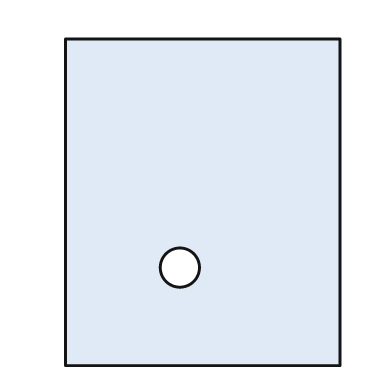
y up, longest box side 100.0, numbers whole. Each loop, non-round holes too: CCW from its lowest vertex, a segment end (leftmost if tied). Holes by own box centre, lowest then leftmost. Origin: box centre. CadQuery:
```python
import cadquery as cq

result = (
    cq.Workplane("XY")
    .moveTo(-42.0, -50.0)
    .lineTo(42.0, -50.0)
    .lineTo(42.0, 50.0)
    .lineTo(-42.0, 50.0)
    .close()
    .moveTo(-7.0, -20.0)
    .circle(6.0)
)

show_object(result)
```